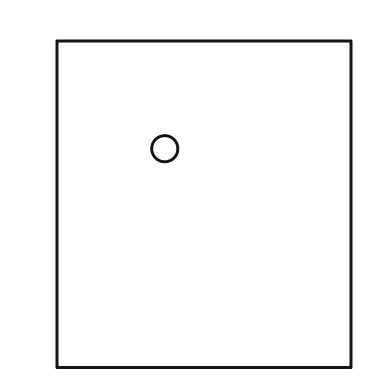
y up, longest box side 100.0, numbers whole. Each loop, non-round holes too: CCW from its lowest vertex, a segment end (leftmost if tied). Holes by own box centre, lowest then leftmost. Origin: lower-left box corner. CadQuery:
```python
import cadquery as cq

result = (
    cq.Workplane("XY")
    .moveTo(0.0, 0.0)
    .lineTo(90.0, 0.0)
    .lineTo(90.0, 100.0)
    .lineTo(0.0, 100.0)
    .close()
    .moveTo(33.0, 67.0)
    .circle(4.0)
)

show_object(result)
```